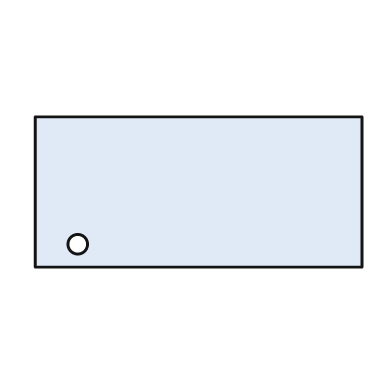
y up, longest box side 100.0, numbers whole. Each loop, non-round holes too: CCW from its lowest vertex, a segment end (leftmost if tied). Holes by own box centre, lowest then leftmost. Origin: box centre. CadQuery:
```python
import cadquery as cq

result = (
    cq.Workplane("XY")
    .moveTo(-50.0, -23.0)
    .lineTo(50.0, -23.0)
    .lineTo(50.0, 23.0)
    .lineTo(-50.0, 23.0)
    .close()
    .moveTo(-37.0, -16.0)
    .circle(3.0)
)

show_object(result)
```